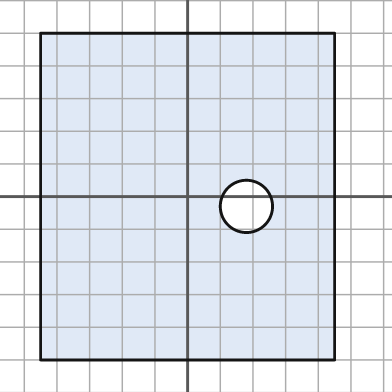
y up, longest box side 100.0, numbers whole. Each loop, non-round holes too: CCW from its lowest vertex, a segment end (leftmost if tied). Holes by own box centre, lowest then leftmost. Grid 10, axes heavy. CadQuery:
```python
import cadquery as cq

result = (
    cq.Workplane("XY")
    .moveTo(-45.0, -50.0)
    .lineTo(45.0, -50.0)
    .lineTo(45.0, 50.0)
    .lineTo(-45.0, 50.0)
    .close()
    .moveTo(18.0, -3.0)
    .circle(8.0)
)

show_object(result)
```